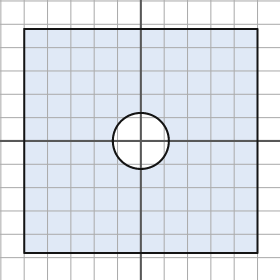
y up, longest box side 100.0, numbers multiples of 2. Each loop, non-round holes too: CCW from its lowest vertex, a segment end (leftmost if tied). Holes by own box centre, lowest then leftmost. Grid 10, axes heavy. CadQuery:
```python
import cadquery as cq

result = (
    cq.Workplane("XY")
    .moveTo(-50.0, -48.0)
    .lineTo(50.0, -48.0)
    .lineTo(50.0, 48.0)
    .lineTo(-50.0, 48.0)
    .close()
    .moveTo(0.0, 0.0)
    .circle(12.0)
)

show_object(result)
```